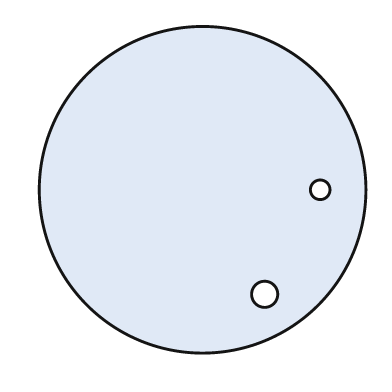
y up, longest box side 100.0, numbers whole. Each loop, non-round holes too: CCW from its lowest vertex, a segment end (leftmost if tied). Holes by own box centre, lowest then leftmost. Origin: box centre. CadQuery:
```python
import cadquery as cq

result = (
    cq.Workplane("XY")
    .moveTo(0.0, 0.0)
    .circle(50.0)
    .moveTo(19.0, -32.0)
    .circle(4.0)
    .moveTo(36.0, 0.0)
    .circle(3.0)
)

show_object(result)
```